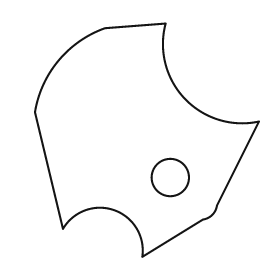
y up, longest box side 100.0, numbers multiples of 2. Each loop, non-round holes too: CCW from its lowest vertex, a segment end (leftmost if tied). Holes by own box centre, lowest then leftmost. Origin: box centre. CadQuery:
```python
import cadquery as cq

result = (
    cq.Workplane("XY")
    .moveTo(-2.0, -50.0)
    .lineTo(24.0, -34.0)
    .threePointArc((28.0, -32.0), (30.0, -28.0))
    .lineTo(48.0, 8.0)
    .threePointArc((16.0, 18.0), (8.0, 50.0))
    .lineTo(-18.0, 48.0)
    .threePointArc((-38.0, 34.0), (-48.0, 12.0))
    .lineTo(-36.0, -38.0)
    .threePointArc((-14.0, -30.0), (-2.0, -50.0))
    .close()
    .moveTo(10.0, -16.0)
    .circle(8.0)
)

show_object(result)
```